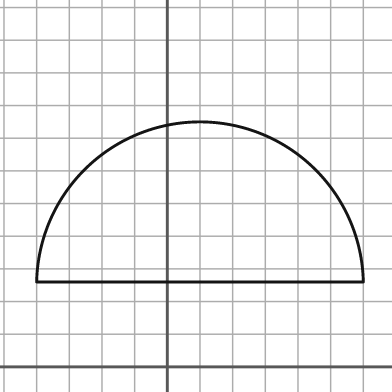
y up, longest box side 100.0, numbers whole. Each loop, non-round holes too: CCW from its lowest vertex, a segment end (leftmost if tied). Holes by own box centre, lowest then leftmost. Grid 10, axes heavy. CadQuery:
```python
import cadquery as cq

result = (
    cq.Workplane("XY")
    .moveTo(-40.0, 26.0)
    .lineTo(60.0, 26.0)
    .threePointArc((10.0, 75.0), (-40.0, 26.0))
    .close()
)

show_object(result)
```